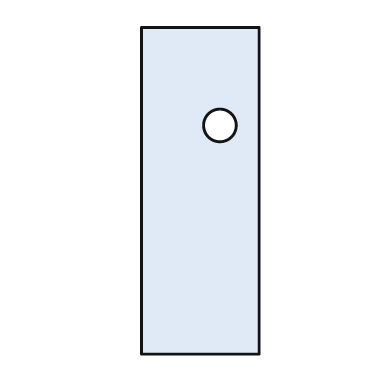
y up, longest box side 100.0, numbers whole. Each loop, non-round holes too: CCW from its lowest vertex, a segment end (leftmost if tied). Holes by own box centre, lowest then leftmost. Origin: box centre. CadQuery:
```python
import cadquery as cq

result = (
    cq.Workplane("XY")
    .moveTo(-18.0, -50.0)
    .lineTo(18.0, -50.0)
    .lineTo(18.0, 50.0)
    .lineTo(-18.0, 50.0)
    .close()
    .moveTo(6.0, 20.0)
    .circle(5.0)
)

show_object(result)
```